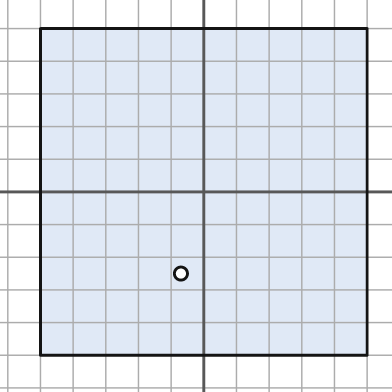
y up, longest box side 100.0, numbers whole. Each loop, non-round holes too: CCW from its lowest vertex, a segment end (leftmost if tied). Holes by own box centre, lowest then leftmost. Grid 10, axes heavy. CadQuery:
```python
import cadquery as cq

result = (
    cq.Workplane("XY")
    .moveTo(-50.0, -50.0)
    .lineTo(50.0, -50.0)
    .lineTo(50.0, 50.0)
    .lineTo(-50.0, 50.0)
    .close()
    .moveTo(-7.0, -25.0)
    .circle(2.0)
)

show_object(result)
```